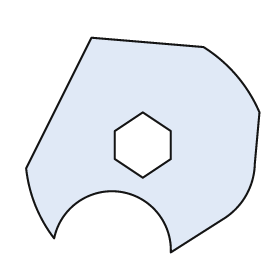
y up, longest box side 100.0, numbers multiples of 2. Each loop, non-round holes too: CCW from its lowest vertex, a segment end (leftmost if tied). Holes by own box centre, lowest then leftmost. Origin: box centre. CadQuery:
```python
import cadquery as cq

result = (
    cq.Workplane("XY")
    .moveTo(12.0, -46.0)
    .lineTo(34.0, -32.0)
    .threePointArc((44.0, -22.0), (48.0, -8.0))
    .lineTo(50.0, 14.0)
    .threePointArc((40.0, 30.0), (26.0, 42.0))
    .lineTo(-22.0, 46.0)
    .lineTo(-50.0, -10.0)
    .threePointArc((-46.0, -26.0), (-38.0, -40.0))
    .threePointArc((-10.0, -20.0), (12.0, -46.0))
    .close()
    .moveTo(0.0, -14.0)
    .lineTo(12.0, -6.0)
    .lineTo(12.0, 6.0)
    .lineTo(0.0, 14.0)
    .lineTo(-12.0, 6.0)
    .lineTo(-12.0, -6.0)
    .close()
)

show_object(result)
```